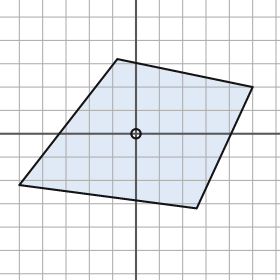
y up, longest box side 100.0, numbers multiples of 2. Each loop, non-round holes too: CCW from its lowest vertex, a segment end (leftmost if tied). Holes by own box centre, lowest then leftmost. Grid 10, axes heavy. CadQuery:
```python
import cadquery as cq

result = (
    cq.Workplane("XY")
    .moveTo(26.0, -32.0)
    .lineTo(50.0, 20.0)
    .lineTo(-8.0, 32.0)
    .lineTo(-50.0, -22.0)
    .close()
    .moveTo(0.0, 0.0)
    .circle(2.0)
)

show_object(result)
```